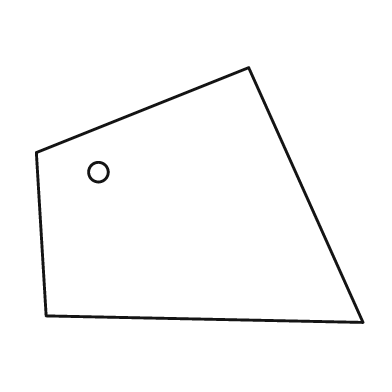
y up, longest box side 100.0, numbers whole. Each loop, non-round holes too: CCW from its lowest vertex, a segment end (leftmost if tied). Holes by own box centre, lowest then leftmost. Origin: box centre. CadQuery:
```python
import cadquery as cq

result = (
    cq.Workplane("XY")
    .moveTo(50.0, -39.0)
    .lineTo(15.0, 39.0)
    .lineTo(-50.0, 13.0)
    .lineTo(-47.0, -37.0)
    .close()
    .moveTo(-31.0, 7.0)
    .circle(3.0)
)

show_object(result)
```